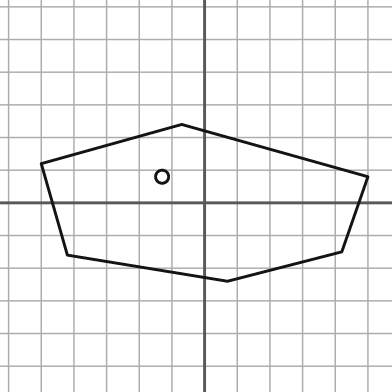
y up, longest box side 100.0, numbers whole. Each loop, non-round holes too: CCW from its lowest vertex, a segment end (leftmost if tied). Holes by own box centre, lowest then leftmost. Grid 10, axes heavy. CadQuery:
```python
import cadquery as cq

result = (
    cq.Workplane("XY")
    .moveTo(7.0, -24.0)
    .lineTo(42.0, -15.0)
    .lineTo(50.0, 8.0)
    .lineTo(-7.0, 24.0)
    .lineTo(-50.0, 12.0)
    .lineTo(-42.0, -16.0)
    .close()
    .moveTo(-13.0, 8.0)
    .circle(2.0)
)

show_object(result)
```